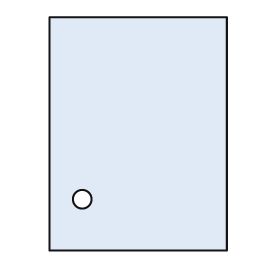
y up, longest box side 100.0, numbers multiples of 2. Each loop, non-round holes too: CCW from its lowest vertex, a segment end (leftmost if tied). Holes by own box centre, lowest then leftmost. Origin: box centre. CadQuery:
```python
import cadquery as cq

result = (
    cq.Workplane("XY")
    .moveTo(-38.0, -50.0)
    .lineTo(38.0, -50.0)
    .lineTo(38.0, 50.0)
    .lineTo(-38.0, 50.0)
    .close()
    .moveTo(-24.0, -28.0)
    .circle(4.0)
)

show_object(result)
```